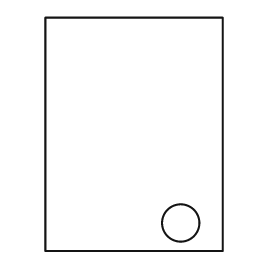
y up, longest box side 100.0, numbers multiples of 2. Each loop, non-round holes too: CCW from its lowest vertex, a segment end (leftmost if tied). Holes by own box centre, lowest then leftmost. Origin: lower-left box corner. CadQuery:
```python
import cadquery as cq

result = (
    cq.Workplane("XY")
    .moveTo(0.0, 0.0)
    .lineTo(76.0, 0.0)
    .lineTo(76.0, 100.0)
    .lineTo(0.0, 100.0)
    .close()
    .moveTo(58.0, 12.0)
    .circle(8.0)
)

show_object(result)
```